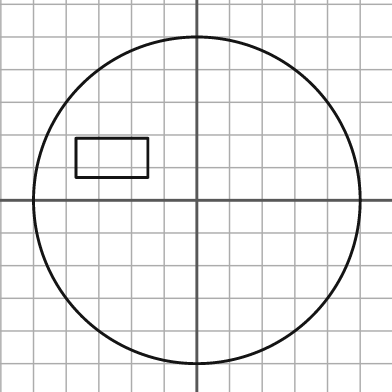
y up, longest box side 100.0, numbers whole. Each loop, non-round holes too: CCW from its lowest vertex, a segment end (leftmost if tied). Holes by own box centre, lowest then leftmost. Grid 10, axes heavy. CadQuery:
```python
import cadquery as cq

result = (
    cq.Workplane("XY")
    .moveTo(0.0, 0.0)
    .circle(50.0)
    .moveTo(-37.0, 7.0)
    .lineTo(-15.0, 7.0)
    .lineTo(-15.0, 19.0)
    .lineTo(-37.0, 19.0)
    .close()
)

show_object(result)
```